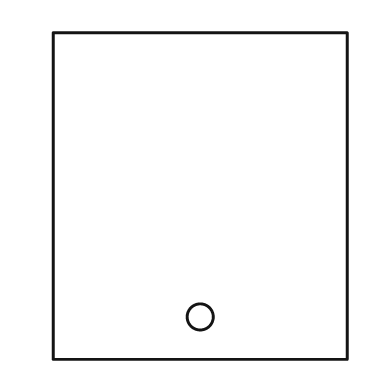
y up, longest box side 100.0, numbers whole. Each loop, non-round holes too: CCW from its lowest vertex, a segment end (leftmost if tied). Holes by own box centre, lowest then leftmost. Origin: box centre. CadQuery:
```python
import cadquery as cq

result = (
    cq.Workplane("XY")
    .moveTo(-45.0, -50.0)
    .lineTo(45.0, -50.0)
    .lineTo(45.0, 50.0)
    .lineTo(-45.0, 50.0)
    .close()
    .moveTo(0.0, -37.0)
    .circle(4.0)
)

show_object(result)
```